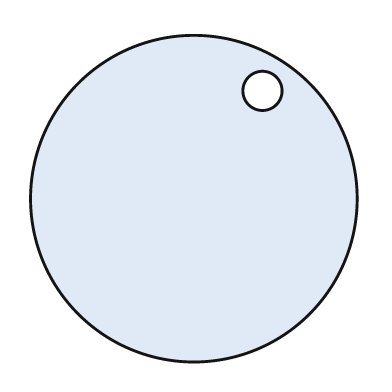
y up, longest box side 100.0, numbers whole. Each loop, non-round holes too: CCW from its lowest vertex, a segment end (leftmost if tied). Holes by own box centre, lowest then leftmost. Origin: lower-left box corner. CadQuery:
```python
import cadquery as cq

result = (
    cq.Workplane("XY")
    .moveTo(50.0, 50.0)
    .circle(50.0)
    .moveTo(71.0, 83.0)
    .circle(6.0)
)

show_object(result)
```